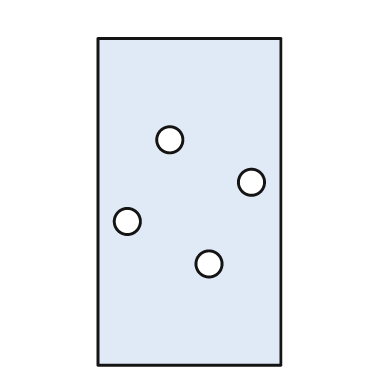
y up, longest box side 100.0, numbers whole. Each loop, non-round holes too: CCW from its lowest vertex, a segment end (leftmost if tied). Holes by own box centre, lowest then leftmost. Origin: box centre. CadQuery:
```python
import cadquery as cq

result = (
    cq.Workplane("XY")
    .moveTo(-28.0, -50.0)
    .lineTo(28.0, -50.0)
    .lineTo(28.0, 50.0)
    .lineTo(-28.0, 50.0)
    .close()
    .moveTo(6.0, -19.0)
    .circle(4.0)
    .moveTo(-19.0, -6.0)
    .circle(4.0)
    .moveTo(19.0, 6.0)
    .circle(4.0)
    .moveTo(-6.0, 19.0)
    .circle(4.0)
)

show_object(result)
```